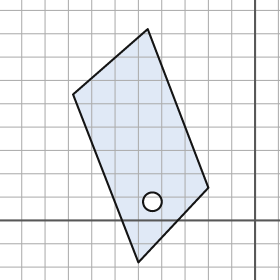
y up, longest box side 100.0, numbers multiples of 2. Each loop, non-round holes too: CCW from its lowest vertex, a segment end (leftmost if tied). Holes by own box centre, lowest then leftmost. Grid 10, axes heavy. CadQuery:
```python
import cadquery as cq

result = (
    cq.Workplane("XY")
    .moveTo(-50.0, -18.0)
    .lineTo(-20.0, 14.0)
    .lineTo(-46.0, 82.0)
    .lineTo(-78.0, 54.0)
    .close()
    .moveTo(-44.0, 8.0)
    .circle(4.0)
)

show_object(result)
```